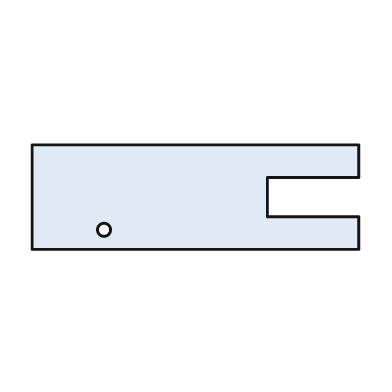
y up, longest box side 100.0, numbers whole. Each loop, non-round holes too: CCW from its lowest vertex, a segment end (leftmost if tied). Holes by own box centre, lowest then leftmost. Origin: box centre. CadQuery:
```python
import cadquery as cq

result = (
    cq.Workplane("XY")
    .moveTo(-50.0, -16.0)
    .lineTo(50.0, -16.0)
    .lineTo(50.0, -6.0)
    .lineTo(22.0, -6.0)
    .lineTo(22.0, 6.0)
    .lineTo(50.0, 6.0)
    .lineTo(50.0, 16.0)
    .lineTo(-50.0, 16.0)
    .close()
    .moveTo(-28.0, -10.0)
    .circle(2.0)
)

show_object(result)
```